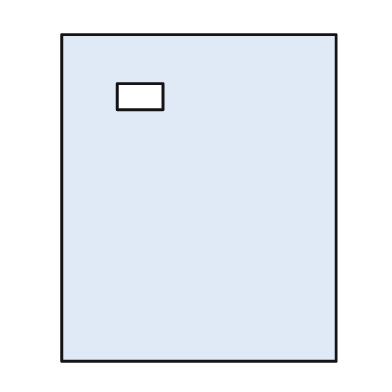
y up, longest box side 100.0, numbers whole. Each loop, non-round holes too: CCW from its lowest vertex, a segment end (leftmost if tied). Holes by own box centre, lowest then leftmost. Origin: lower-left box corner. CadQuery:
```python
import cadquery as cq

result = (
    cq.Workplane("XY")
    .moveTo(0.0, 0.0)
    .lineTo(84.0, 0.0)
    .lineTo(84.0, 100.0)
    .lineTo(0.0, 100.0)
    .close()
    .moveTo(17.0, 77.0)
    .lineTo(31.0, 77.0)
    .lineTo(31.0, 85.0)
    .lineTo(17.0, 85.0)
    .close()
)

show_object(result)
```